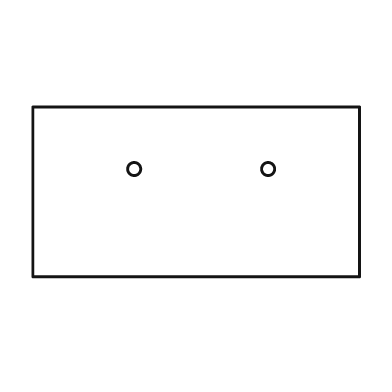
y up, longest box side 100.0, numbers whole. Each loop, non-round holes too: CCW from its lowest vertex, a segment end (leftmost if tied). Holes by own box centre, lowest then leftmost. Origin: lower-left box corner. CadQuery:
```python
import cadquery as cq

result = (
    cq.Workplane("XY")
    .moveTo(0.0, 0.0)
    .lineTo(100.0, 0.0)
    .lineTo(100.0, 52.0)
    .lineTo(0.0, 52.0)
    .close()
    .moveTo(31.0, 33.0)
    .circle(2.0)
    .moveTo(72.0, 33.0)
    .circle(2.0)
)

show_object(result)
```